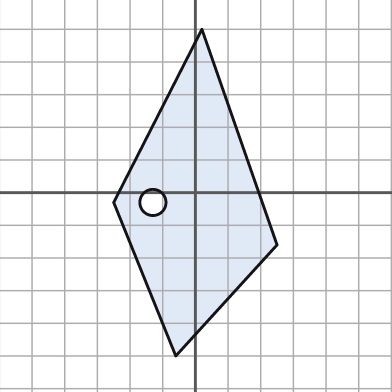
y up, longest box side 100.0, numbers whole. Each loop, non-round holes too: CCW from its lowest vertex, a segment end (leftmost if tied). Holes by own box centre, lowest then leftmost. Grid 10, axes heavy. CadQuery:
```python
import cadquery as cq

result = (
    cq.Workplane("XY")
    .moveTo(-6.0, -50.0)
    .lineTo(25.0, -16.0)
    .lineTo(2.0, 50.0)
    .lineTo(-25.0, -3.0)
    .close()
    .moveTo(-13.0, -3.0)
    .circle(4.0)
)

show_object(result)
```